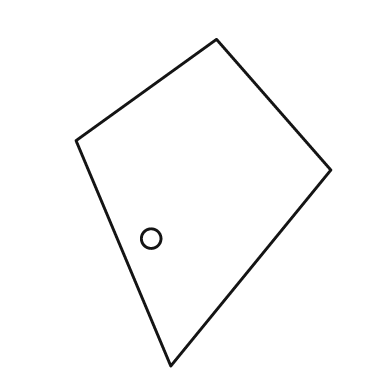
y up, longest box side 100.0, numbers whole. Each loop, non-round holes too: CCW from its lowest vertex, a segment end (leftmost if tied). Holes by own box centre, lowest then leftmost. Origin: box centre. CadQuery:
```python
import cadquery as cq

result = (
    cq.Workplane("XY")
    .moveTo(-10.0, -50.0)
    .lineTo(39.0, 10.0)
    .lineTo(4.0, 50.0)
    .lineTo(-39.0, 19.0)
    .close()
    .moveTo(-16.0, -11.0)
    .circle(3.0)
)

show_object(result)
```